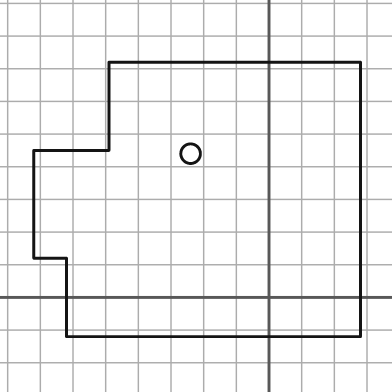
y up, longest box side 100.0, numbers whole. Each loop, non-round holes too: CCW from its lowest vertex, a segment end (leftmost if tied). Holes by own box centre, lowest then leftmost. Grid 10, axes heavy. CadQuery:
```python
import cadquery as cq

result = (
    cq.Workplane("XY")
    .moveTo(-62.0, -12.0)
    .lineTo(28.0, -12.0)
    .lineTo(28.0, 72.0)
    .lineTo(-49.0, 72.0)
    .lineTo(-49.0, 45.0)
    .lineTo(-72.0, 45.0)
    .lineTo(-72.0, 12.0)
    .lineTo(-62.0, 12.0)
    .close()
    .moveTo(-24.0, 44.0)
    .circle(3.0)
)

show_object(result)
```